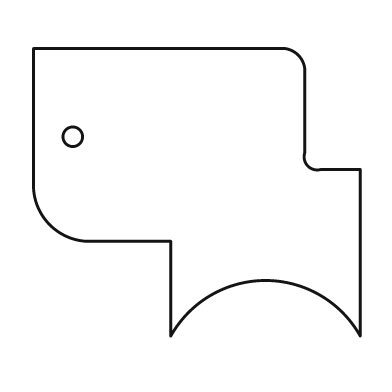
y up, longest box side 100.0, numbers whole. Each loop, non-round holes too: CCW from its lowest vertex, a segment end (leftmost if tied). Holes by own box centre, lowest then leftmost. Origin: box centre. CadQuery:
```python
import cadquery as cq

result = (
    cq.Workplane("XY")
    .moveTo(-8.0, -44.0)
    .threePointArc((21.0, -27.0), (50.0, -44.0))
    .lineTo(50.0, 7.0)
    .lineTo(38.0, 7.0)
    .threePointArc((34.0, 8.0), (33.0, 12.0))
    .lineTo(33.0, 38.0)
    .threePointArc((31.0, 42.0), (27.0, 44.0))
    .lineTo(-50.0, 44.0)
    .lineTo(-50.0, 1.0)
    .threePointArc((-45.0, -10.0), (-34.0, -15.0))
    .lineTo(-8.0, -15.0)
    .close()
    .moveTo(-38.0, 17.0)
    .circle(3.0)
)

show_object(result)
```